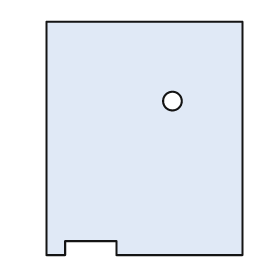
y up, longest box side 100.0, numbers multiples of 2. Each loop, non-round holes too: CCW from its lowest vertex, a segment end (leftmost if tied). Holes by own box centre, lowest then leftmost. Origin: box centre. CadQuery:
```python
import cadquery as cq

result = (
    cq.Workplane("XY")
    .moveTo(-42.0, -50.0)
    .lineTo(-34.0, -50.0)
    .lineTo(-34.0, -44.0)
    .lineTo(-12.0, -44.0)
    .lineTo(-12.0, -50.0)
    .lineTo(42.0, -50.0)
    .lineTo(42.0, 50.0)
    .lineTo(-42.0, 50.0)
    .close()
    .moveTo(12.0, 16.0)
    .circle(4.0)
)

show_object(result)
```